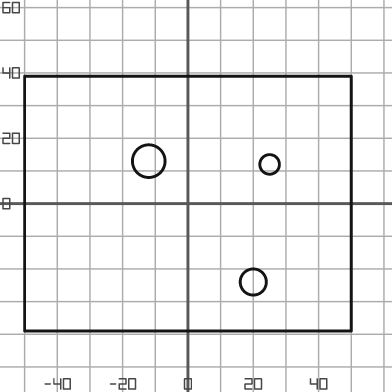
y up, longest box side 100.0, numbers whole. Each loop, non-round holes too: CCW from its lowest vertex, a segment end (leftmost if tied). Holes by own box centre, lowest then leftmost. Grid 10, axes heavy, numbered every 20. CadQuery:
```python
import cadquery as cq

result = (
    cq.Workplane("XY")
    .moveTo(-50.0, -39.0)
    .lineTo(50.0, -39.0)
    .lineTo(50.0, 39.0)
    .lineTo(-50.0, 39.0)
    .close()
    .moveTo(20.0, -24.0)
    .circle(4.0)
    .moveTo(25.0, 12.0)
    .circle(3.0)
    .moveTo(-12.0, 13.0)
    .circle(5.0)
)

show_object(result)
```